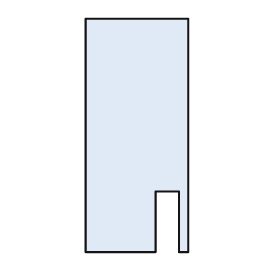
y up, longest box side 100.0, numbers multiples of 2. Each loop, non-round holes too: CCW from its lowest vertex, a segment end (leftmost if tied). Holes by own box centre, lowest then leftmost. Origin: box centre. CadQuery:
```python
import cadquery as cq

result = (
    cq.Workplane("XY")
    .moveTo(-22.0, -50.0)
    .lineTo(8.0, -50.0)
    .lineTo(8.0, -24.0)
    .lineTo(18.0, -24.0)
    .lineTo(18.0, -50.0)
    .lineTo(22.0, -50.0)
    .lineTo(22.0, 50.0)
    .lineTo(-22.0, 50.0)
    .close()
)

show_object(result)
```